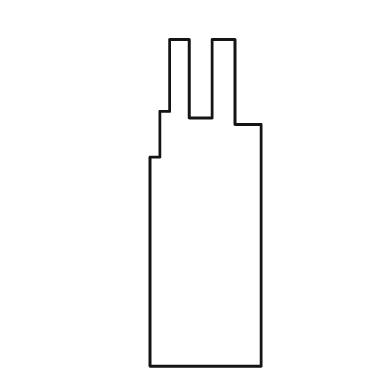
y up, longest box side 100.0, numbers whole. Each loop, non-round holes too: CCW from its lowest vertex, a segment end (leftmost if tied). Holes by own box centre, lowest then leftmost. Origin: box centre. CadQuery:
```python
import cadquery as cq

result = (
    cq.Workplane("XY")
    .moveTo(-17.0, -50.0)
    .lineTo(17.0, -50.0)
    .lineTo(17.0, 24.0)
    .lineTo(9.0, 24.0)
    .lineTo(9.0, 50.0)
    .lineTo(2.0, 50.0)
    .lineTo(2.0, 26.0)
    .lineTo(-5.0, 26.0)
    .lineTo(-5.0, 50.0)
    .lineTo(-11.0, 50.0)
    .lineTo(-11.0, 28.0)
    .lineTo(-14.0, 28.0)
    .lineTo(-14.0, 14.0)
    .lineTo(-17.0, 14.0)
    .close()
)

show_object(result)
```